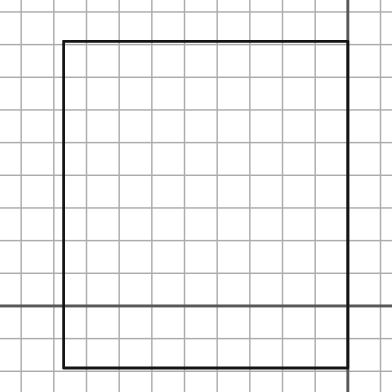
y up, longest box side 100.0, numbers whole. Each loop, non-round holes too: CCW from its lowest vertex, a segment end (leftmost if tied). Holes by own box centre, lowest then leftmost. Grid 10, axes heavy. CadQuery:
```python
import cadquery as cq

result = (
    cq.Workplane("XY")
    .moveTo(-87.0, -19.0)
    .lineTo(0.0, -19.0)
    .lineTo(0.0, 81.0)
    .lineTo(-87.0, 81.0)
    .close()
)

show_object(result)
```